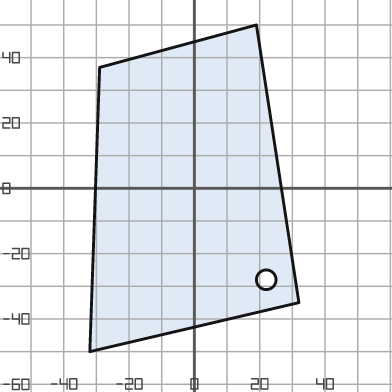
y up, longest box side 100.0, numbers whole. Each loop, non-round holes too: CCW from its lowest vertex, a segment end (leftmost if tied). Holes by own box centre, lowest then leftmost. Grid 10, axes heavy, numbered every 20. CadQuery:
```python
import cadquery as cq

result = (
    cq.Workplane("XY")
    .moveTo(-32.0, -50.0)
    .lineTo(32.0, -35.0)
    .lineTo(19.0, 50.0)
    .lineTo(-29.0, 37.0)
    .close()
    .moveTo(22.0, -28.0)
    .circle(3.0)
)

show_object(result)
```